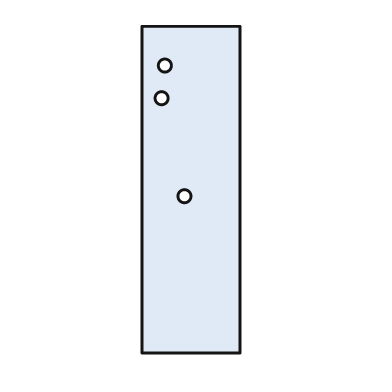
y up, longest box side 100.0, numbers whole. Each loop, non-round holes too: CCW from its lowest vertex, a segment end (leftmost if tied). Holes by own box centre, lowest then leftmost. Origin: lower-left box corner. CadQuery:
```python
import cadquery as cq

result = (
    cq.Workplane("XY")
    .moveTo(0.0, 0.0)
    .lineTo(30.0, 0.0)
    .lineTo(30.0, 100.0)
    .lineTo(0.0, 100.0)
    .close()
    .moveTo(13.0, 48.0)
    .circle(2.0)
    .moveTo(6.0, 78.0)
    .circle(2.0)
    .moveTo(7.0, 88.0)
    .circle(2.0)
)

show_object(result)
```